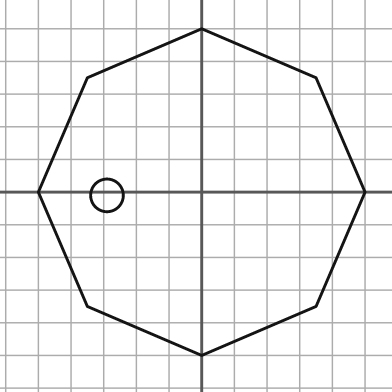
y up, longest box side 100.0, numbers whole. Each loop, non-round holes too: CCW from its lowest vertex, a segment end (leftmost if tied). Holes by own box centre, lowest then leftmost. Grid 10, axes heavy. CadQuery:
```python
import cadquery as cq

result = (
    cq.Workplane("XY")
    .moveTo(0.0, -50.0)
    .lineTo(35.0, -35.0)
    .lineTo(50.0, 0.0)
    .lineTo(35.0, 35.0)
    .lineTo(0.0, 50.0)
    .lineTo(-35.0, 35.0)
    .lineTo(-50.0, 0.0)
    .lineTo(-35.0, -35.0)
    .close()
    .moveTo(-29.0, -1.0)
    .circle(5.0)
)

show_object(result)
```